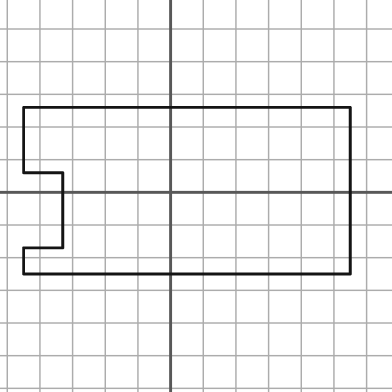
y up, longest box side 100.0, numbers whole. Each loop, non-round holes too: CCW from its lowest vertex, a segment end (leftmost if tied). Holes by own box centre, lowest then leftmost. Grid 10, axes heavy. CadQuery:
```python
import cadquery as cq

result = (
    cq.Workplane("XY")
    .moveTo(-45.0, -25.0)
    .lineTo(55.0, -25.0)
    .lineTo(55.0, 26.0)
    .lineTo(-45.0, 26.0)
    .lineTo(-45.0, 6.0)
    .lineTo(-33.0, 6.0)
    .lineTo(-33.0, -17.0)
    .lineTo(-45.0, -17.0)
    .close()
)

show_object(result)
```